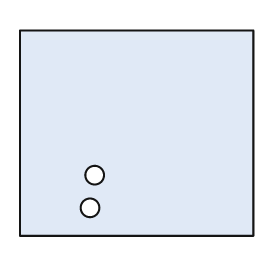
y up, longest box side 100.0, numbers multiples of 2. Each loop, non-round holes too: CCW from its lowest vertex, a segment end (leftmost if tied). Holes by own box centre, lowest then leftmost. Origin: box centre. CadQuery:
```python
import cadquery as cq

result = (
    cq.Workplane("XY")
    .moveTo(-50.0, -44.0)
    .lineTo(50.0, -44.0)
    .lineTo(50.0, 44.0)
    .lineTo(-50.0, 44.0)
    .close()
    .moveTo(-20.0, -32.0)
    .circle(4.0)
    .moveTo(-18.0, -18.0)
    .circle(4.0)
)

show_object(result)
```